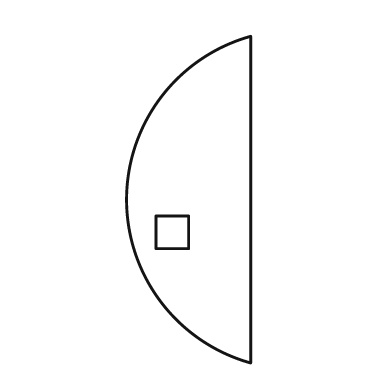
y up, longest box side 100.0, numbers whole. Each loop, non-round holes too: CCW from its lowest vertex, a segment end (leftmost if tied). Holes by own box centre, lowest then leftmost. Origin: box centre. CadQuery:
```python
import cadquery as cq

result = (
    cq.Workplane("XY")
    .moveTo(19.0, -50.0)
    .lineTo(19.0, 50.0)
    .threePointArc((-19.0, 0.0), (19.0, -50.0))
    .close()
    .moveTo(-10.0, -15.0)
    .lineTo(0.0, -15.0)
    .lineTo(0.0, -5.0)
    .lineTo(-10.0, -5.0)
    .close()
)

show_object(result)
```